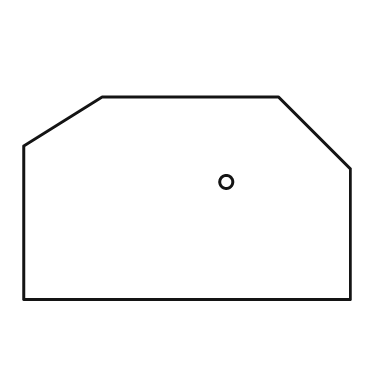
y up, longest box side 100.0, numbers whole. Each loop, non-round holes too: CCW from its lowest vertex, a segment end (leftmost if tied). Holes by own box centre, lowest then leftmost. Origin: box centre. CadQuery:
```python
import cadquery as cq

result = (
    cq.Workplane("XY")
    .moveTo(-50.0, -31.0)
    .lineTo(50.0, -31.0)
    .lineTo(50.0, 9.0)
    .lineTo(28.0, 31.0)
    .lineTo(-26.0, 31.0)
    .lineTo(-50.0, 16.0)
    .close()
    .moveTo(12.0, 5.0)
    .circle(2.0)
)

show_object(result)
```